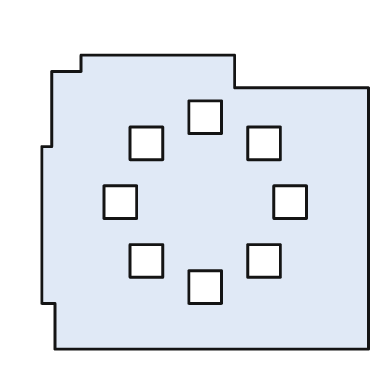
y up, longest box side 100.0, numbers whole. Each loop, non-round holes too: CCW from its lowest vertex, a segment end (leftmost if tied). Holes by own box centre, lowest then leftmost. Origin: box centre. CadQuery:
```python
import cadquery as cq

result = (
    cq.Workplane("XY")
    .moveTo(-46.0, -45.0)
    .lineTo(50.0, -45.0)
    .lineTo(50.0, 35.0)
    .lineTo(9.0, 35.0)
    .lineTo(9.0, 45.0)
    .lineTo(-38.0, 45.0)
    .lineTo(-38.0, 40.0)
    .lineTo(-47.0, 40.0)
    .lineTo(-47.0, 17.0)
    .lineTo(-50.0, 17.0)
    .lineTo(-50.0, -31.0)
    .lineTo(-46.0, -31.0)
    .close()
    .moveTo(-5.0, -31.0)
    .lineTo(5.0, -31.0)
    .lineTo(5.0, -21.0)
    .lineTo(-5.0, -21.0)
    .close()
    .moveTo(-23.0, -23.0)
    .lineTo(-13.0, -23.0)
    .lineTo(-13.0, -13.0)
    .lineTo(-23.0, -13.0)
    .close()
    .moveTo(13.0, -23.0)
    .lineTo(23.0, -23.0)
    .lineTo(23.0, -13.0)
    .lineTo(13.0, -13.0)
    .close()
    .moveTo(-31.0, -5.0)
    .lineTo(-21.0, -5.0)
    .lineTo(-21.0, 5.0)
    .lineTo(-31.0, 5.0)
    .close()
    .moveTo(21.0, -5.0)
    .lineTo(31.0, -5.0)
    .lineTo(31.0, 5.0)
    .lineTo(21.0, 5.0)
    .close()
    .moveTo(-23.0, 13.0)
    .lineTo(-13.0, 13.0)
    .lineTo(-13.0, 23.0)
    .lineTo(-23.0, 23.0)
    .close()
    .moveTo(13.0, 13.0)
    .lineTo(23.0, 13.0)
    .lineTo(23.0, 23.0)
    .lineTo(13.0, 23.0)
    .close()
    .moveTo(-5.0, 21.0)
    .lineTo(5.0, 21.0)
    .lineTo(5.0, 31.0)
    .lineTo(-5.0, 31.0)
    .close()
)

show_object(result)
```